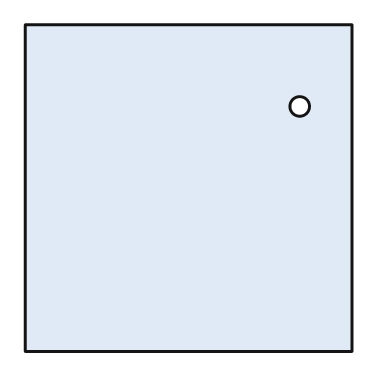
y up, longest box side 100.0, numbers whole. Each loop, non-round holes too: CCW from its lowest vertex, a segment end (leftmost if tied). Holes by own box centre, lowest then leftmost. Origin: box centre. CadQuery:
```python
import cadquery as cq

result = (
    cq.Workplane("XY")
    .moveTo(-50.0, -50.0)
    .lineTo(50.0, -50.0)
    .lineTo(50.0, 50.0)
    .lineTo(-50.0, 50.0)
    .close()
    .moveTo(34.0, 25.0)
    .circle(3.0)
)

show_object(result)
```